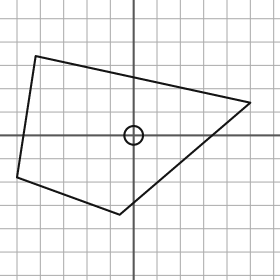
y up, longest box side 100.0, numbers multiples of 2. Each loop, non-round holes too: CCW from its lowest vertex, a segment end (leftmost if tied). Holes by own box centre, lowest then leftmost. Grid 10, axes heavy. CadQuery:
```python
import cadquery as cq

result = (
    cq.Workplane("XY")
    .moveTo(-6.0, -34.0)
    .lineTo(50.0, 14.0)
    .lineTo(-42.0, 34.0)
    .lineTo(-50.0, -18.0)
    .close()
    .moveTo(0.0, 0.0)
    .circle(4.0)
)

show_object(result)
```